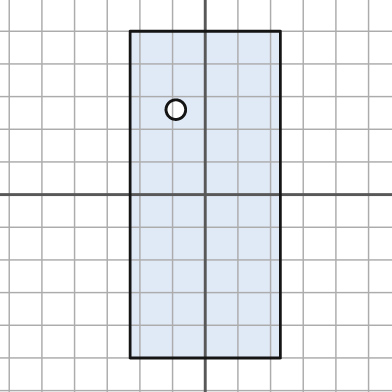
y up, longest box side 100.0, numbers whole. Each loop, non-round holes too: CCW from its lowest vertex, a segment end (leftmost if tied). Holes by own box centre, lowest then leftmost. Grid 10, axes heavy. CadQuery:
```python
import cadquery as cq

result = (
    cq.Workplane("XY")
    .moveTo(-23.0, -50.0)
    .lineTo(23.0, -50.0)
    .lineTo(23.0, 50.0)
    .lineTo(-23.0, 50.0)
    .close()
    .moveTo(-9.0, 26.0)
    .circle(3.0)
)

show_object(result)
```